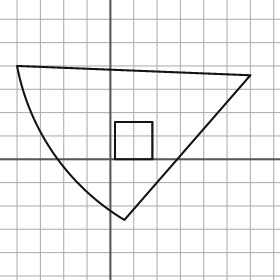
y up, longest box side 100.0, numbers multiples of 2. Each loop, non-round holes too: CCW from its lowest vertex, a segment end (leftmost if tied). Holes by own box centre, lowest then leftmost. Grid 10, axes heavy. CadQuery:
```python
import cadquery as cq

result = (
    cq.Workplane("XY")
    .moveTo(6.0, -26.0)
    .lineTo(60.0, 36.0)
    .lineTo(-40.0, 40.0)
    .threePointArc((-24.0, 2.0), (6.0, -26.0))
    .close()
    .moveTo(2.0, 0.0)
    .lineTo(18.0, 0.0)
    .lineTo(18.0, 16.0)
    .lineTo(2.0, 16.0)
    .close()
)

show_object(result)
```